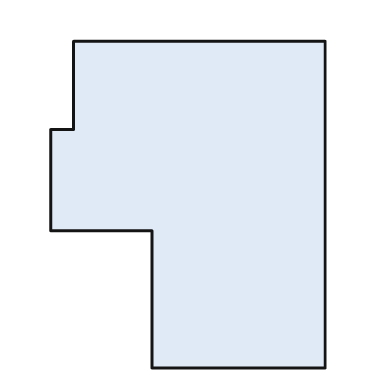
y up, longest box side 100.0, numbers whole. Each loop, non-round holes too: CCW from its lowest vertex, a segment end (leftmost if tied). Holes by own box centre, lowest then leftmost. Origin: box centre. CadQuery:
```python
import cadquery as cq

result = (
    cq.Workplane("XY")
    .moveTo(-11.0, -50.0)
    .lineTo(42.0, -50.0)
    .lineTo(42.0, 50.0)
    .lineTo(-35.0, 50.0)
    .lineTo(-35.0, 23.0)
    .lineTo(-42.0, 23.0)
    .lineTo(-42.0, -8.0)
    .lineTo(-11.0, -8.0)
    .close()
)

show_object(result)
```